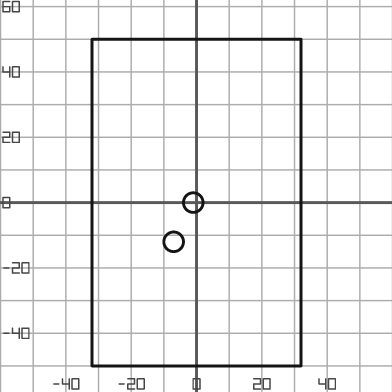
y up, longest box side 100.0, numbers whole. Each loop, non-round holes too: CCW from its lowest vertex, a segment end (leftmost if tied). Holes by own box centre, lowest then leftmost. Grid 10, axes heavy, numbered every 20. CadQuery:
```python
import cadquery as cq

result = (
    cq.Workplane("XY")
    .moveTo(-32.0, -50.0)
    .lineTo(32.0, -50.0)
    .lineTo(32.0, 50.0)
    .lineTo(-32.0, 50.0)
    .close()
    .moveTo(-7.0, -12.0)
    .circle(3.0)
    .moveTo(-1.0, 0.0)
    .circle(3.0)
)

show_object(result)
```